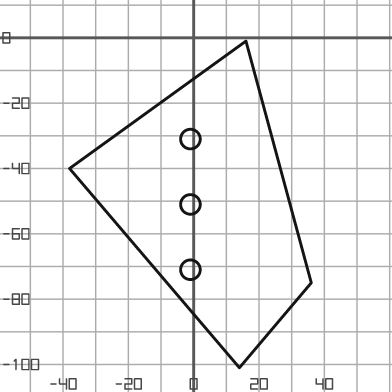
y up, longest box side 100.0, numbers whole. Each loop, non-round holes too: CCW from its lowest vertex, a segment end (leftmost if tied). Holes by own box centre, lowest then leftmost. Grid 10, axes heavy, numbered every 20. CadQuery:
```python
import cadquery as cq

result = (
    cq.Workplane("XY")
    .moveTo(14.0, -101.0)
    .lineTo(36.0, -75.0)
    .lineTo(16.0, -1.0)
    .lineTo(-38.0, -40.0)
    .close()
    .moveTo(-1.0, -71.0)
    .circle(3.0)
    .moveTo(-1.0, -51.0)
    .circle(3.0)
    .moveTo(-1.0, -31.0)
    .circle(3.0)
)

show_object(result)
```